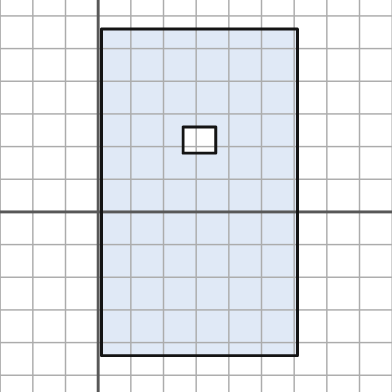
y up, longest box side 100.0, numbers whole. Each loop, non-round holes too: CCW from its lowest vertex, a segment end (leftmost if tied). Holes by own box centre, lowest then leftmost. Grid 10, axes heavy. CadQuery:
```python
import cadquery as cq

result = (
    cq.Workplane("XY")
    .moveTo(1.0, -44.0)
    .lineTo(61.0, -44.0)
    .lineTo(61.0, 56.0)
    .lineTo(1.0, 56.0)
    .close()
    .moveTo(26.0, 18.0)
    .lineTo(36.0, 18.0)
    .lineTo(36.0, 26.0)
    .lineTo(26.0, 26.0)
    .close()
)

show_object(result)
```